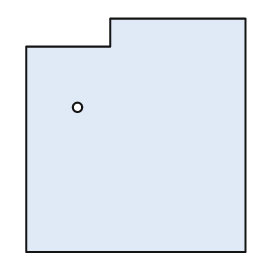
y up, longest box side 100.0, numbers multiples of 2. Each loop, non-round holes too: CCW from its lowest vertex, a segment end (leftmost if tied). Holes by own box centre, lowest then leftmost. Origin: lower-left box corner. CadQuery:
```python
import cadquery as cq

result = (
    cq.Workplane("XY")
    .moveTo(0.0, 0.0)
    .lineTo(94.0, 0.0)
    .lineTo(94.0, 100.0)
    .lineTo(36.0, 100.0)
    .lineTo(36.0, 88.0)
    .lineTo(0.0, 88.0)
    .close()
    .moveTo(22.0, 62.0)
    .circle(2.0)
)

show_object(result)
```